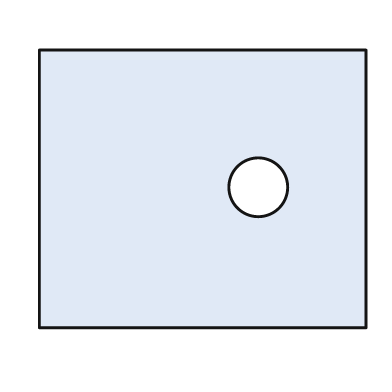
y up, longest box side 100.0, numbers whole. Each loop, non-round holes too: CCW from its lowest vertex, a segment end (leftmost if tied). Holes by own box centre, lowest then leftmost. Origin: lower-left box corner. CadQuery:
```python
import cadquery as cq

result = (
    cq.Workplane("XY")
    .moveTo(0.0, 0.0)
    .lineTo(100.0, 0.0)
    .lineTo(100.0, 85.0)
    .lineTo(0.0, 85.0)
    .close()
    .moveTo(67.0, 43.0)
    .circle(9.0)
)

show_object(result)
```